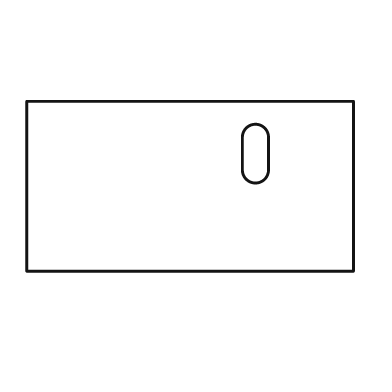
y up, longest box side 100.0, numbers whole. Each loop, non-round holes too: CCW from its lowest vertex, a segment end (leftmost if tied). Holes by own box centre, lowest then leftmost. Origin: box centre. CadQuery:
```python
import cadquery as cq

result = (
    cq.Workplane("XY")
    .moveTo(-50.0, -26.0)
    .lineTo(50.0, -26.0)
    .lineTo(50.0, 26.0)
    .lineTo(-50.0, 26.0)
    .close()
    .moveTo(16.0, 5.0)
    .threePointArc((20.0, 1.0), (24.0, 5.0))
    .lineTo(24.0, 15.0)
    .threePointArc((20.0, 19.0), (16.0, 15.0))
    .close()
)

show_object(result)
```